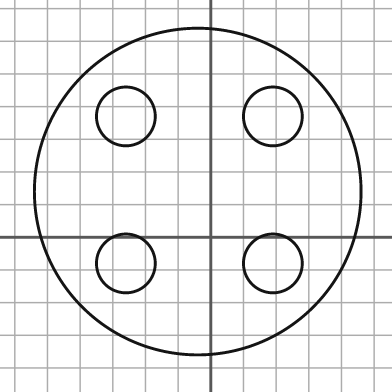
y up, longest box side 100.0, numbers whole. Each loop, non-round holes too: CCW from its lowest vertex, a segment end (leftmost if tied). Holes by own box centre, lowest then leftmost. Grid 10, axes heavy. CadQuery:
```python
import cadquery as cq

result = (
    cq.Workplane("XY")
    .moveTo(-4.0, 14.0)
    .circle(50.0)
    .moveTo(-26.0, -8.0)
    .circle(9.0)
    .moveTo(19.0, -8.0)
    .circle(9.0)
    .moveTo(-26.0, 37.0)
    .circle(9.0)
    .moveTo(19.0, 37.0)
    .circle(9.0)
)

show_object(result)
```